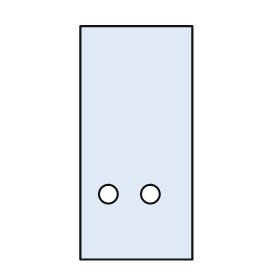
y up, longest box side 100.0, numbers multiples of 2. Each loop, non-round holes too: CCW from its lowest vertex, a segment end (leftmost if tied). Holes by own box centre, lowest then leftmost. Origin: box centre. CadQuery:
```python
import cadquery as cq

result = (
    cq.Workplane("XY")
    .moveTo(-24.0, -50.0)
    .lineTo(24.0, -50.0)
    .lineTo(24.0, 50.0)
    .lineTo(-24.0, 50.0)
    .close()
    .moveTo(-12.0, -22.0)
    .circle(4.0)
    .moveTo(6.0, -22.0)
    .circle(4.0)
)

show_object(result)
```